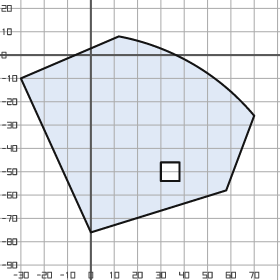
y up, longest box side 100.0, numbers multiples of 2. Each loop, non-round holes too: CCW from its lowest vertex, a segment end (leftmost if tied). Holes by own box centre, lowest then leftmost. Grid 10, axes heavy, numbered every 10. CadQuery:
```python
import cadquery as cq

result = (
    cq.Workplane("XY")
    .moveTo(0.0, -76.0)
    .lineTo(58.0, -58.0)
    .lineTo(70.0, -26.0)
    .threePointArc((44.0, -4.0), (12.0, 8.0))
    .lineTo(-30.0, -10.0)
    .close()
    .moveTo(30.0, -54.0)
    .lineTo(38.0, -54.0)
    .lineTo(38.0, -46.0)
    .lineTo(30.0, -46.0)
    .close()
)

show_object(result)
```